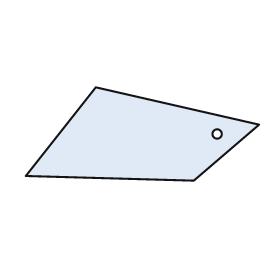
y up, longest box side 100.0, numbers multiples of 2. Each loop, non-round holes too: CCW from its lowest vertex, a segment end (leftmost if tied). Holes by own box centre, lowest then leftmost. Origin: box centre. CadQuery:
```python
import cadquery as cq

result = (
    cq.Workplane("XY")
    .moveTo(22.0, -20.0)
    .lineTo(50.0, 4.0)
    .lineTo(-20.0, 20.0)
    .lineTo(-50.0, -18.0)
    .close()
    .moveTo(32.0, 0.0)
    .circle(2.0)
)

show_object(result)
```